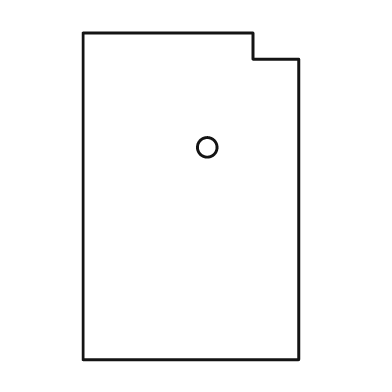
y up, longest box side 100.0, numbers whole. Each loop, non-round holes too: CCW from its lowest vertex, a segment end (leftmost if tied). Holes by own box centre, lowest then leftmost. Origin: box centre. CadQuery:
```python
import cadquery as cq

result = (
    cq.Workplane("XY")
    .moveTo(-33.0, -50.0)
    .lineTo(33.0, -50.0)
    .lineTo(33.0, 42.0)
    .lineTo(19.0, 42.0)
    .lineTo(19.0, 50.0)
    .lineTo(-33.0, 50.0)
    .close()
    .moveTo(5.0, 15.0)
    .circle(3.0)
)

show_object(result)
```